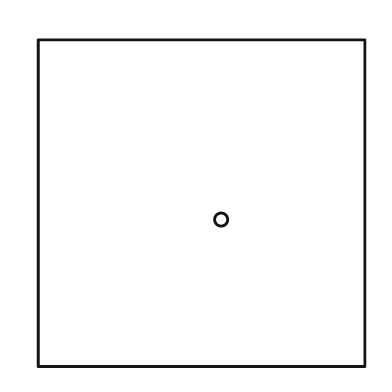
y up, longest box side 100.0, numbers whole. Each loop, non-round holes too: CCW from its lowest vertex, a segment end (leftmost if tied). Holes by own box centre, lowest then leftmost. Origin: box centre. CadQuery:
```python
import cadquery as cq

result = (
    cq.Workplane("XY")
    .moveTo(-50.0, -50.0)
    .lineTo(50.0, -50.0)
    .lineTo(50.0, 50.0)
    .lineTo(-50.0, 50.0)
    .close()
    .moveTo(6.0, -5.0)
    .circle(2.0)
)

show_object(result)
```